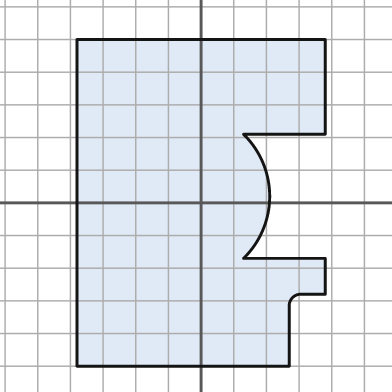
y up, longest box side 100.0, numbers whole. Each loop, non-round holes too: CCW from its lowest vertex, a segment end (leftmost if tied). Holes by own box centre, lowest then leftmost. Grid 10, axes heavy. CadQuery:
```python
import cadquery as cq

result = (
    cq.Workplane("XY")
    .moveTo(-38.0, -50.0)
    .lineTo(27.0, -50.0)
    .lineTo(27.0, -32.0)
    .threePointArc((28.0, -29.0), (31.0, -28.0))
    .lineTo(38.0, -28.0)
    .lineTo(38.0, -17.0)
    .lineTo(13.0, -17.0)
    .threePointArc((21.0, 2.0), (13.0, 21.0))
    .lineTo(38.0, 21.0)
    .lineTo(38.0, 50.0)
    .lineTo(-38.0, 50.0)
    .close()
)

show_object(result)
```